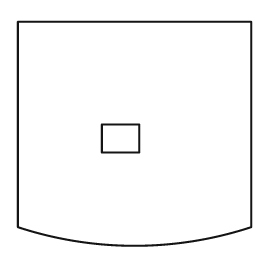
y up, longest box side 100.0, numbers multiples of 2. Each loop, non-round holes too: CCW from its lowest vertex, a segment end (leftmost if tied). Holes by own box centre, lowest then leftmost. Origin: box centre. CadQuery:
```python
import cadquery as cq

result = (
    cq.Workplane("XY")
    .moveTo(-50.0, -40.0)
    .threePointArc((0.0, -48.0), (50.0, -40.0))
    .lineTo(50.0, 48.0)
    .lineTo(-50.0, 48.0)
    .close()
    .moveTo(-14.0, -8.0)
    .lineTo(2.0, -8.0)
    .lineTo(2.0, 4.0)
    .lineTo(-14.0, 4.0)
    .close()
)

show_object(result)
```